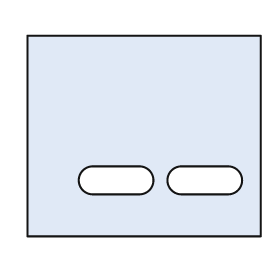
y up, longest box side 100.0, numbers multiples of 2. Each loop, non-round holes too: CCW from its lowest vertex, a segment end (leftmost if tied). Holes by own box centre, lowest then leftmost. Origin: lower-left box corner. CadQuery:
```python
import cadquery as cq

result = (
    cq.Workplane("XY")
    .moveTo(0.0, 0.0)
    .lineTo(100.0, 0.0)
    .lineTo(100.0, 86.0)
    .lineTo(0.0, 86.0)
    .close()
    .moveTo(28.0, 18.0)
    .lineTo(48.0, 18.0)
    .threePointArc((54.0, 24.0), (48.0, 30.0))
    .lineTo(28.0, 30.0)
    .threePointArc((22.0, 24.0), (28.0, 18.0))
    .close()
    .moveTo(66.0, 18.0)
    .lineTo(86.0, 18.0)
    .threePointArc((92.0, 24.0), (86.0, 30.0))
    .lineTo(66.0, 30.0)
    .threePointArc((60.0, 24.0), (66.0, 18.0))
    .close()
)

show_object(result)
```